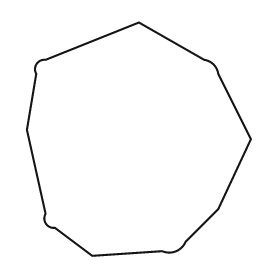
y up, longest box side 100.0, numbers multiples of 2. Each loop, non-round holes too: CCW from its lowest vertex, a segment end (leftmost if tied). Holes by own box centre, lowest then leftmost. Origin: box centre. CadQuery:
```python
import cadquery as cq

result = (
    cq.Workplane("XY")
    .moveTo(-20.0, -50.0)
    .lineTo(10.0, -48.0)
    .threePointArc((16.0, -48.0), (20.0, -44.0))
    .lineTo(34.0, -30.0)
    .lineTo(48.0, 0.0)
    .lineTo(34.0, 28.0)
    .threePointArc((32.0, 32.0), (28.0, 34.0))
    .lineTo(0.0, 50.0)
    .lineTo(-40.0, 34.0)
    .threePointArc((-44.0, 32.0), (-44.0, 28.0))
    .lineTo(-48.0, 4.0)
    .lineTo(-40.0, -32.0)
    .threePointArc((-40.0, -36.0), (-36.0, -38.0))
    .close()
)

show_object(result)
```